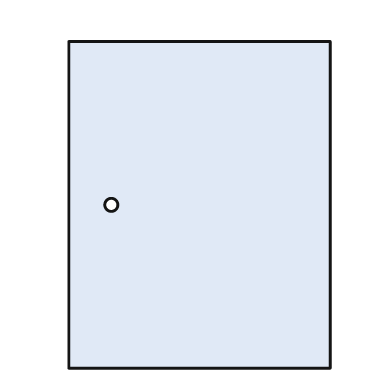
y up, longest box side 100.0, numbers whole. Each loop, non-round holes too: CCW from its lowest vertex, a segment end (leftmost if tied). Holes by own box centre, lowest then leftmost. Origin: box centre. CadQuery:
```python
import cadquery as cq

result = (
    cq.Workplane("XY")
    .moveTo(-40.0, -50.0)
    .lineTo(40.0, -50.0)
    .lineTo(40.0, 50.0)
    .lineTo(-40.0, 50.0)
    .close()
    .moveTo(-27.0, 0.0)
    .circle(2.0)
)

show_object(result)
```